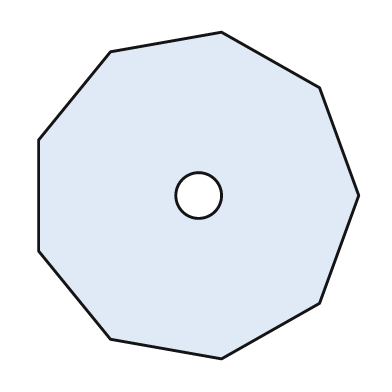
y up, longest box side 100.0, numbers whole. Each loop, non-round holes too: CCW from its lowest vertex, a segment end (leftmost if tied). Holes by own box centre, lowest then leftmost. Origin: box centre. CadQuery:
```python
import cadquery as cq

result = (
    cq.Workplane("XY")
    .moveTo(7.0, -50.0)
    .lineTo(37.0, -33.0)
    .lineTo(49.0, 0.0)
    .lineTo(37.0, 33.0)
    .lineTo(7.0, 50.0)
    .lineTo(-27.0, 44.0)
    .lineTo(-49.0, 17.0)
    .lineTo(-49.0, -17.0)
    .lineTo(-27.0, -44.0)
    .close()
    .moveTo(0.0, 0.0)
    .circle(7.0)
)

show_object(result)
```